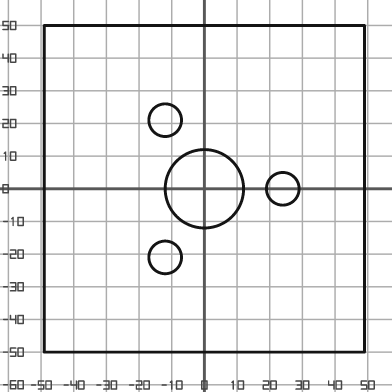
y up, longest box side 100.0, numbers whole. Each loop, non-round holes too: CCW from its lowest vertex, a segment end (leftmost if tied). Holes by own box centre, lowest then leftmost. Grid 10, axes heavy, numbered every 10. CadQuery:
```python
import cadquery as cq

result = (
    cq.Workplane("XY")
    .moveTo(-49.0, -50.0)
    .lineTo(49.0, -50.0)
    .lineTo(49.0, 50.0)
    .lineTo(-49.0, 50.0)
    .close()
    .moveTo(-12.0, -21.0)
    .circle(5.0)
    .moveTo(0.0, 0.0)
    .circle(12.0)
    .moveTo(24.0, 0.0)
    .circle(5.0)
    .moveTo(-12.0, 21.0)
    .circle(5.0)
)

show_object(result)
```